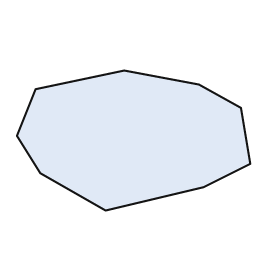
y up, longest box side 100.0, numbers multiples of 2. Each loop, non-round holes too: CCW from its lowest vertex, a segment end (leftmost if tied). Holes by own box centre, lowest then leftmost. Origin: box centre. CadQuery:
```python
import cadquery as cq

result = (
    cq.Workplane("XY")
    .moveTo(-12.0, -30.0)
    .lineTo(30.0, -20.0)
    .lineTo(50.0, -10.0)
    .lineTo(46.0, 14.0)
    .lineTo(28.0, 24.0)
    .lineTo(-4.0, 30.0)
    .lineTo(-42.0, 22.0)
    .lineTo(-50.0, 2.0)
    .lineTo(-40.0, -14.0)
    .close()
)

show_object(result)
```